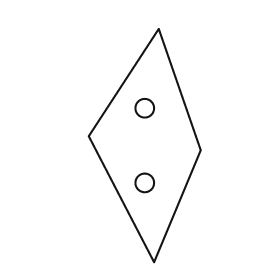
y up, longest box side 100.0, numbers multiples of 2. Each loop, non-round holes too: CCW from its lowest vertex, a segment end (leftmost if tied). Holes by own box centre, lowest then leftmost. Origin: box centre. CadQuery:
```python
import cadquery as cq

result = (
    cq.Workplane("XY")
    .moveTo(4.0, -50.0)
    .lineTo(24.0, -2.0)
    .lineTo(6.0, 50.0)
    .lineTo(-24.0, 4.0)
    .close()
    .moveTo(0.0, -16.0)
    .circle(4.0)
    .moveTo(0.0, 16.0)
    .circle(4.0)
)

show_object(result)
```